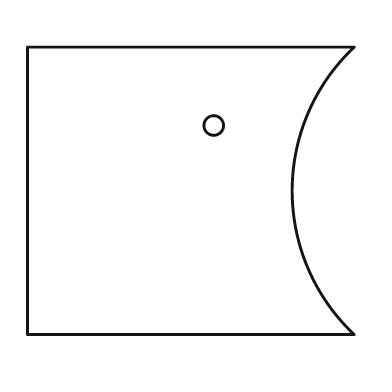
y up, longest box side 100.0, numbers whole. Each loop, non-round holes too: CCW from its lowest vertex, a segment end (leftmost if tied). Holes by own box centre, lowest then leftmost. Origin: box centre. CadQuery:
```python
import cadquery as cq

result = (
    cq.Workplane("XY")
    .moveTo(-50.0, -44.0)
    .lineTo(50.0, -44.0)
    .threePointArc((31.0, 0.0), (50.0, 44.0))
    .lineTo(-50.0, 44.0)
    .close()
    .moveTo(7.0, 20.0)
    .circle(3.0)
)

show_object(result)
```